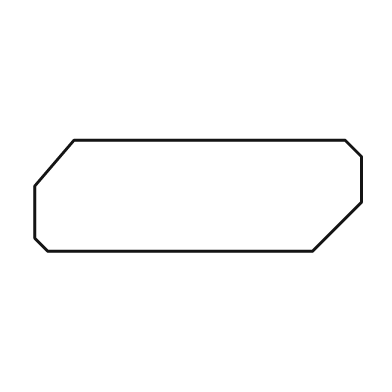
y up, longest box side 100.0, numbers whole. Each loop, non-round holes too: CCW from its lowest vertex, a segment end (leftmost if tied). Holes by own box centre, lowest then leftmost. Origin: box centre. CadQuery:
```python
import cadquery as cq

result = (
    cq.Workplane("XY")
    .moveTo(-46.0, -17.0)
    .lineTo(35.0, -17.0)
    .lineTo(50.0, -2.0)
    .lineTo(50.0, 12.0)
    .lineTo(45.0, 17.0)
    .lineTo(-38.0, 17.0)
    .lineTo(-50.0, 3.0)
    .lineTo(-50.0, -13.0)
    .close()
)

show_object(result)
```